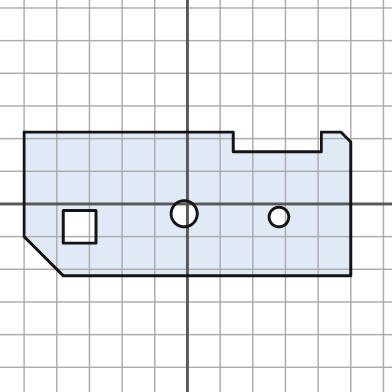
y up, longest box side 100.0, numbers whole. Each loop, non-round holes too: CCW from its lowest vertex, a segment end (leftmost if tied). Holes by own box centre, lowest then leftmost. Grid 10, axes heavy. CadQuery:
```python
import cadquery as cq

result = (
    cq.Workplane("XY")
    .moveTo(-38.0, -22.0)
    .lineTo(50.0, -22.0)
    .lineTo(50.0, 19.0)
    .lineTo(47.0, 22.0)
    .lineTo(41.0, 22.0)
    .lineTo(41.0, 16.0)
    .lineTo(14.0, 16.0)
    .lineTo(14.0, 22.0)
    .lineTo(-50.0, 22.0)
    .lineTo(-50.0, -10.0)
    .close()
    .moveTo(-38.0, -12.0)
    .lineTo(-28.0, -12.0)
    .lineTo(-28.0, -2.0)
    .lineTo(-38.0, -2.0)
    .close()
    .moveTo(28.0, -4.0)
    .circle(3.0)
    .moveTo(-1.0, -3.0)
    .circle(4.0)
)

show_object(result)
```